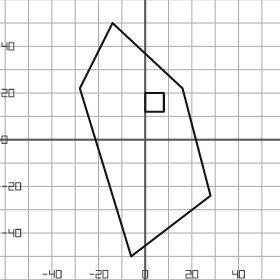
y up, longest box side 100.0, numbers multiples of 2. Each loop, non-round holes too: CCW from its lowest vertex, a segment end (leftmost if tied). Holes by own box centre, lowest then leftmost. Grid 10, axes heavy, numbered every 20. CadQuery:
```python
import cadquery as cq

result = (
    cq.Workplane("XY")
    .moveTo(-6.0, -50.0)
    .lineTo(28.0, -24.0)
    .lineTo(16.0, 22.0)
    .lineTo(-14.0, 50.0)
    .lineTo(-28.0, 22.0)
    .close()
    .moveTo(0.0, 12.0)
    .lineTo(8.0, 12.0)
    .lineTo(8.0, 20.0)
    .lineTo(0.0, 20.0)
    .close()
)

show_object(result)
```